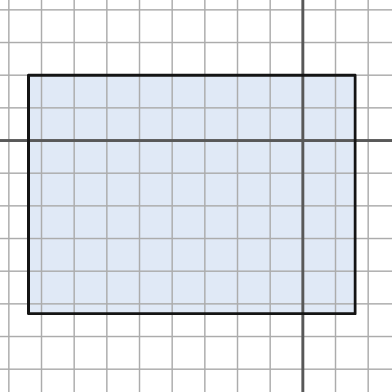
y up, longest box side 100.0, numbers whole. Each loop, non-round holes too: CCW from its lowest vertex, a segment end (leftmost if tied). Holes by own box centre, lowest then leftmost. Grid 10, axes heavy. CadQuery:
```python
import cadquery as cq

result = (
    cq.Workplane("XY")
    .moveTo(-84.0, -53.0)
    .lineTo(16.0, -53.0)
    .lineTo(16.0, 20.0)
    .lineTo(-84.0, 20.0)
    .close()
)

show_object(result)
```